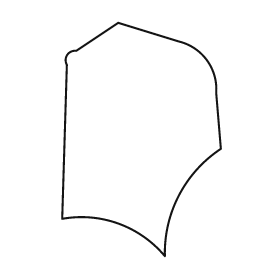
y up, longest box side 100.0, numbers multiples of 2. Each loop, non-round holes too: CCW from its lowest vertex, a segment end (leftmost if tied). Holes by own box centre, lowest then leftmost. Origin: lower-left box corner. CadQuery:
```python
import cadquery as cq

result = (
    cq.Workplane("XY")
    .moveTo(44.0, 0.0)
    .threePointArc((50.0, 26.0), (68.0, 46.0))
    .lineTo(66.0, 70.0)
    .threePointArc((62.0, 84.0), (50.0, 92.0))
    .lineTo(24.0, 100.0)
    .lineTo(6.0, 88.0)
    .threePointArc((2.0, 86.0), (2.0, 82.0))
    .lineTo(0.0, 16.0)
    .threePointArc((24.0, 14.0), (44.0, 0.0))
    .close()
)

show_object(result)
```